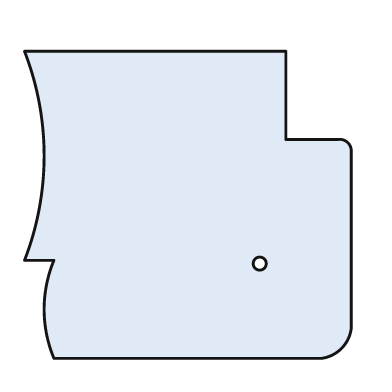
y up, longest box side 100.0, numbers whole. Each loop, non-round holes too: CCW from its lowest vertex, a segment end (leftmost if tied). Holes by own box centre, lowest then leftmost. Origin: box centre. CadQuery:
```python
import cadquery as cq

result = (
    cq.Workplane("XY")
    .moveTo(-41.0, -47.0)
    .lineTo(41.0, -47.0)
    .threePointArc((47.0, -44.0), (50.0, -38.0))
    .lineTo(50.0, 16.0)
    .threePointArc((49.0, 19.0), (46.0, 20.0))
    .lineTo(30.0, 20.0)
    .lineTo(30.0, 47.0)
    .lineTo(-50.0, 47.0)
    .threePointArc((-44.0, 15.0), (-50.0, -17.0))
    .lineTo(-41.0, -17.0)
    .threePointArc((-44.0, -32.0), (-41.0, -47.0))
    .close()
    .moveTo(22.0, -18.0)
    .circle(2.0)
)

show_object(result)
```